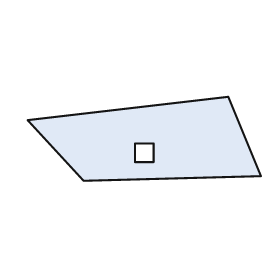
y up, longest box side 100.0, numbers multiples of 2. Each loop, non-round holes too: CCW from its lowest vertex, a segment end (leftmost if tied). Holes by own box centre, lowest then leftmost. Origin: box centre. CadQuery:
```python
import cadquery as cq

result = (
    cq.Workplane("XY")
    .moveTo(-26.0, -18.0)
    .lineTo(50.0, -16.0)
    .lineTo(36.0, 18.0)
    .lineTo(-50.0, 8.0)
    .close()
    .moveTo(-4.0, -10.0)
    .lineTo(4.0, -10.0)
    .lineTo(4.0, -2.0)
    .lineTo(-4.0, -2.0)
    .close()
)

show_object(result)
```